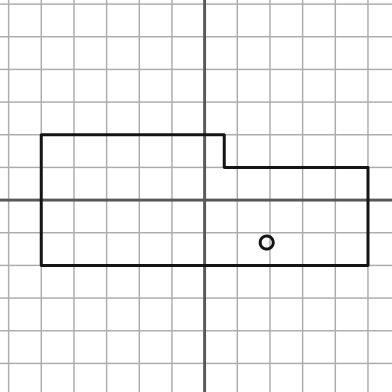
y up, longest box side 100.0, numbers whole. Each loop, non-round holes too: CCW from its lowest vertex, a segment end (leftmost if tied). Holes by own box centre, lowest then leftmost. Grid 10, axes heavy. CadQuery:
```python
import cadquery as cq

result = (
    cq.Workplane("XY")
    .moveTo(-50.0, -20.0)
    .lineTo(50.0, -20.0)
    .lineTo(50.0, 10.0)
    .lineTo(6.0, 10.0)
    .lineTo(6.0, 20.0)
    .lineTo(-50.0, 20.0)
    .close()
    .moveTo(19.0, -13.0)
    .circle(2.0)
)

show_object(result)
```